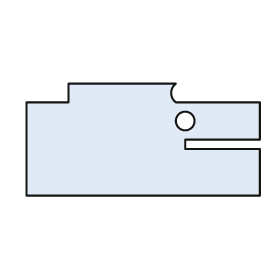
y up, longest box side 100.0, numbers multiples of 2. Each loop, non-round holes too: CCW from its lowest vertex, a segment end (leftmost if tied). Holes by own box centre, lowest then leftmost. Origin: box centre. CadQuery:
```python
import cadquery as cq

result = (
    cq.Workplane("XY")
    .moveTo(-50.0, -24.0)
    .lineTo(50.0, -24.0)
    .lineTo(50.0, -4.0)
    .lineTo(18.0, -4.0)
    .lineTo(18.0, 0.0)
    .lineTo(50.0, 0.0)
    .lineTo(50.0, 16.0)
    .lineTo(14.0, 16.0)
    .threePointArc((12.0, 20.0), (14.0, 24.0))
    .lineTo(-32.0, 24.0)
    .lineTo(-32.0, 16.0)
    .lineTo(-50.0, 16.0)
    .close()
    .moveTo(18.0, 8.0)
    .circle(4.0)
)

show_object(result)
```